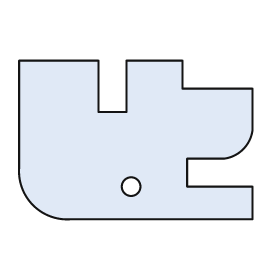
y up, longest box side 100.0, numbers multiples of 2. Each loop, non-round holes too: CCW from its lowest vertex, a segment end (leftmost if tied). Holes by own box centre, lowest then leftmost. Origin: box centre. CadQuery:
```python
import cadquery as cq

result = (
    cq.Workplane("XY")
    .moveTo(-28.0, -34.0)
    .lineTo(50.0, -34.0)
    .lineTo(50.0, -20.0)
    .lineTo(22.0, -20.0)
    .lineTo(22.0, -8.0)
    .lineTo(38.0, -8.0)
    .threePointArc((46.0, -4.0), (50.0, 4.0))
    .lineTo(50.0, 22.0)
    .lineTo(20.0, 22.0)
    .lineTo(20.0, 34.0)
    .lineTo(-4.0, 34.0)
    .lineTo(-4.0, 12.0)
    .lineTo(-16.0, 12.0)
    .lineTo(-16.0, 34.0)
    .lineTo(-50.0, 34.0)
    .lineTo(-50.0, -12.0)
    .threePointArc((-44.0, -28.0), (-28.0, -34.0))
    .close()
    .moveTo(-2.0, -20.0)
    .circle(4.0)
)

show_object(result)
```